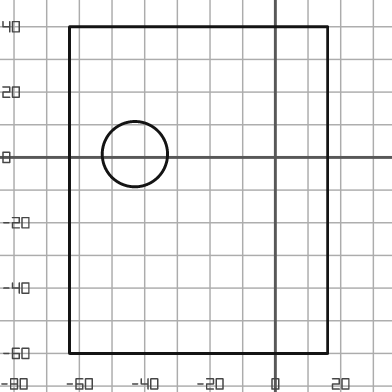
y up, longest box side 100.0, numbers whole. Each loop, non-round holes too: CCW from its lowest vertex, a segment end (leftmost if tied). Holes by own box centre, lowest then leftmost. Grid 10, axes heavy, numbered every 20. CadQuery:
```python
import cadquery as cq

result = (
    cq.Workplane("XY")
    .moveTo(-63.0, -60.0)
    .lineTo(16.0, -60.0)
    .lineTo(16.0, 40.0)
    .lineTo(-63.0, 40.0)
    .close()
    .moveTo(-43.0, 1.0)
    .circle(10.0)
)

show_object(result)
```